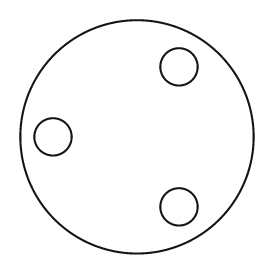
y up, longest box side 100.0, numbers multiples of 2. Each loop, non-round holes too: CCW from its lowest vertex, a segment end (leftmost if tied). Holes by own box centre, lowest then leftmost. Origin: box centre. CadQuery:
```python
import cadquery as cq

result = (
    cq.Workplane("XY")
    .moveTo(0.0, 0.0)
    .circle(50.0)
    .moveTo(18.0, -30.0)
    .circle(8.0)
    .moveTo(-36.0, 0.0)
    .circle(8.0)
    .moveTo(18.0, 30.0)
    .circle(8.0)
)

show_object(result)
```